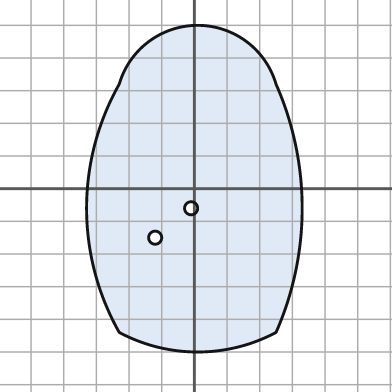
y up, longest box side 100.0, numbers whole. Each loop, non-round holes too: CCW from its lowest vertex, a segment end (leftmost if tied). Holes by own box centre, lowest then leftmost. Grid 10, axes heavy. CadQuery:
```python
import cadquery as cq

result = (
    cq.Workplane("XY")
    .moveTo(-23.0, -44.0)
    .threePointArc((1.0, -50.0), (25.0, -44.0))
    .threePointArc((33.0, -6.0), (25.0, 32.0))
    .threePointArc((1.0, 50.0), (-23.0, 32.0))
    .threePointArc((-33.0, -6.0), (-23.0, -44.0))
    .close()
    .moveTo(-12.0, -15.0)
    .circle(2.0)
    .moveTo(-1.0, -6.0)
    .circle(2.0)
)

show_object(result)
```